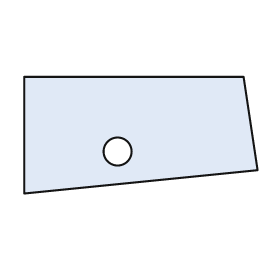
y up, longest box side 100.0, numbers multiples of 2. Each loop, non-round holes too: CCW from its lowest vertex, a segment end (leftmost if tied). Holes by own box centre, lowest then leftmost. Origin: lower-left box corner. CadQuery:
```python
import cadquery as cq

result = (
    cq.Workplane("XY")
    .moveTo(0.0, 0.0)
    .lineTo(100.0, 10.0)
    .lineTo(94.0, 50.0)
    .lineTo(0.0, 50.0)
    .close()
    .moveTo(40.0, 18.0)
    .circle(6.0)
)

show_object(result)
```